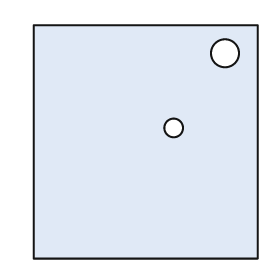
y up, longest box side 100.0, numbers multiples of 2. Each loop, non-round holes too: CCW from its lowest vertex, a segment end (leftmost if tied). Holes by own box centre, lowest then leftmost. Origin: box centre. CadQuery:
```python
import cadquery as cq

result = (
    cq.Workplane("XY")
    .moveTo(-48.0, -50.0)
    .lineTo(48.0, -50.0)
    .lineTo(48.0, 50.0)
    .lineTo(-48.0, 50.0)
    .close()
    .moveTo(12.0, 6.0)
    .circle(4.0)
    .moveTo(34.0, 38.0)
    .circle(6.0)
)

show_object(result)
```